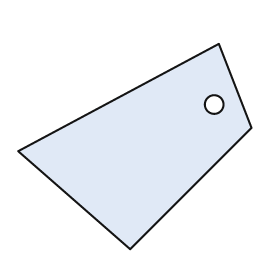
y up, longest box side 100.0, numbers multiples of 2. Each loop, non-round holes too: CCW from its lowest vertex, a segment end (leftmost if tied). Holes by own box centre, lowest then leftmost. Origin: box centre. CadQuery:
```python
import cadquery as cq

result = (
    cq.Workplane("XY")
    .moveTo(-2.0, -44.0)
    .lineTo(50.0, 8.0)
    .lineTo(36.0, 44.0)
    .lineTo(-50.0, -2.0)
    .close()
    .moveTo(34.0, 18.0)
    .circle(4.0)
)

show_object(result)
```